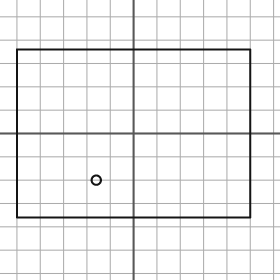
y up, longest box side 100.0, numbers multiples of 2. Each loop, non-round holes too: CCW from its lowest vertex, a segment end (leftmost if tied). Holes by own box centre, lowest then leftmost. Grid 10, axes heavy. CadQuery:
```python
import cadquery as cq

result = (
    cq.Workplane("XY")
    .moveTo(-50.0, -36.0)
    .lineTo(50.0, -36.0)
    .lineTo(50.0, 36.0)
    .lineTo(-50.0, 36.0)
    .close()
    .moveTo(-16.0, -20.0)
    .circle(2.0)
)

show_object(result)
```